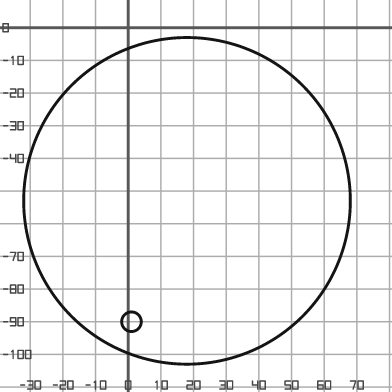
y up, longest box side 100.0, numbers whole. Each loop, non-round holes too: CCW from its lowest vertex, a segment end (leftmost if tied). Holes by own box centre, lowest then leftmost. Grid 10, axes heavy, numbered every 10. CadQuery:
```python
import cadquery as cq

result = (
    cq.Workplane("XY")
    .moveTo(18.0, -53.0)
    .circle(50.0)
    .moveTo(1.0, -90.0)
    .circle(3.0)
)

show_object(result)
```